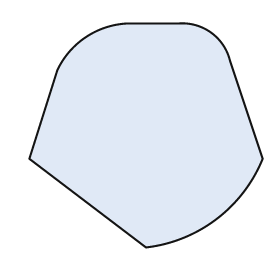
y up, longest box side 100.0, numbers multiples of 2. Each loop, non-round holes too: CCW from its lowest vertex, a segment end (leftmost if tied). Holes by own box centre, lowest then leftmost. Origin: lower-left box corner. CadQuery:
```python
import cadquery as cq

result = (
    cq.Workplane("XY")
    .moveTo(50.0, 0.0)
    .threePointArc((80.0, 12.0), (100.0, 38.0))
    .lineTo(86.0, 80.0)
    .threePointArc((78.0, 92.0), (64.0, 96.0))
    .lineTo(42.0, 96.0)
    .threePointArc((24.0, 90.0), (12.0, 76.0))
    .lineTo(0.0, 38.0)
    .close()
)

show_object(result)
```